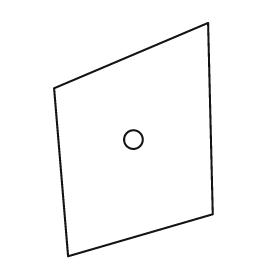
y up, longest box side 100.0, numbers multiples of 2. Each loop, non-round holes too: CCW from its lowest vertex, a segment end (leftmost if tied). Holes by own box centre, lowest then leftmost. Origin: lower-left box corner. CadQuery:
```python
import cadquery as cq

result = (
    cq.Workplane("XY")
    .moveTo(6.0, 0.0)
    .lineTo(68.0, 18.0)
    .lineTo(66.0, 100.0)
    .lineTo(0.0, 72.0)
    .close()
    .moveTo(34.0, 50.0)
    .circle(4.0)
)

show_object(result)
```